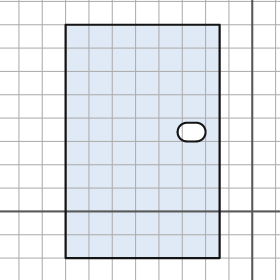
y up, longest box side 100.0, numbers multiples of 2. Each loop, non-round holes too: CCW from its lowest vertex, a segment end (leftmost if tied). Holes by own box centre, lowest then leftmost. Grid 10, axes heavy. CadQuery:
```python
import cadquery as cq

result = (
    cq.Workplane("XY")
    .moveTo(-80.0, -20.0)
    .lineTo(-14.0, -20.0)
    .lineTo(-14.0, 80.0)
    .lineTo(-80.0, 80.0)
    .close()
    .moveTo(-28.0, 30.0)
    .lineTo(-24.0, 30.0)
    .threePointArc((-20.0, 34.0), (-24.0, 38.0))
    .lineTo(-28.0, 38.0)
    .threePointArc((-32.0, 34.0), (-28.0, 30.0))
    .close()
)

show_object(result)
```